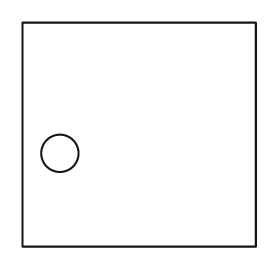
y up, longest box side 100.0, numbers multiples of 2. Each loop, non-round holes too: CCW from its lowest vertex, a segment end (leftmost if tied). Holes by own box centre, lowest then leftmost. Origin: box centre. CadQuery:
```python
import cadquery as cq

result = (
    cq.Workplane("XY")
    .moveTo(-50.0, -48.0)
    .lineTo(50.0, -48.0)
    .lineTo(50.0, 48.0)
    .lineTo(-50.0, 48.0)
    .close()
    .moveTo(-34.0, -8.0)
    .circle(8.0)
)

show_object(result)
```